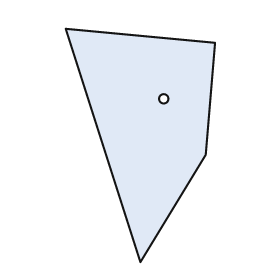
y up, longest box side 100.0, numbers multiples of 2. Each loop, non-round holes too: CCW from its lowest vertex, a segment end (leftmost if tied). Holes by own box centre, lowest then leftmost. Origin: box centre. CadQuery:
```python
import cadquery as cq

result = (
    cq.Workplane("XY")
    .moveTo(0.0, -50.0)
    .lineTo(28.0, -4.0)
    .lineTo(32.0, 44.0)
    .lineTo(-32.0, 50.0)
    .close()
    .moveTo(10.0, 20.0)
    .circle(2.0)
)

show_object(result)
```